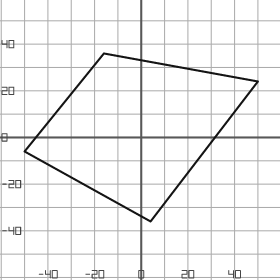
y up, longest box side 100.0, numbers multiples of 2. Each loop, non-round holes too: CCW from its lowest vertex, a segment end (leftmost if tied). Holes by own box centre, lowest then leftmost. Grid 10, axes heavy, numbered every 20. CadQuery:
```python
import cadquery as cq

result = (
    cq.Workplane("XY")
    .moveTo(4.0, -36.0)
    .lineTo(50.0, 24.0)
    .lineTo(-16.0, 36.0)
    .lineTo(-50.0, -6.0)
    .close()
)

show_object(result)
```